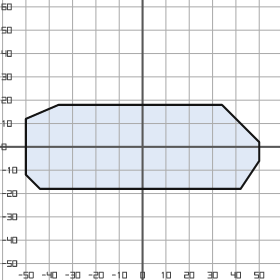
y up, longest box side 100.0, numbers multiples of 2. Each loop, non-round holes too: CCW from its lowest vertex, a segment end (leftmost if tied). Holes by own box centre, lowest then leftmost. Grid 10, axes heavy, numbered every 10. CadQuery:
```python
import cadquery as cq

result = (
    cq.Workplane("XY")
    .moveTo(-44.0, -18.0)
    .lineTo(42.0, -18.0)
    .lineTo(50.0, -6.0)
    .lineTo(50.0, 2.0)
    .lineTo(34.0, 18.0)
    .lineTo(-36.0, 18.0)
    .lineTo(-50.0, 12.0)
    .lineTo(-50.0, -12.0)
    .close()
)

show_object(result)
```